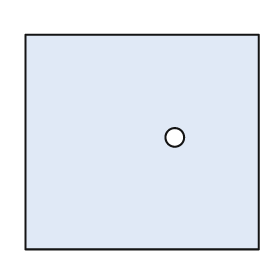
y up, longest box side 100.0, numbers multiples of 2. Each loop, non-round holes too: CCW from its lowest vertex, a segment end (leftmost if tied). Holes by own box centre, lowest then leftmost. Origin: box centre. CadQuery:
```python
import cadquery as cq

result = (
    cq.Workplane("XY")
    .moveTo(-50.0, -46.0)
    .lineTo(50.0, -46.0)
    .lineTo(50.0, 46.0)
    .lineTo(-50.0, 46.0)
    .close()
    .moveTo(14.0, 2.0)
    .circle(4.0)
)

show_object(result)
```